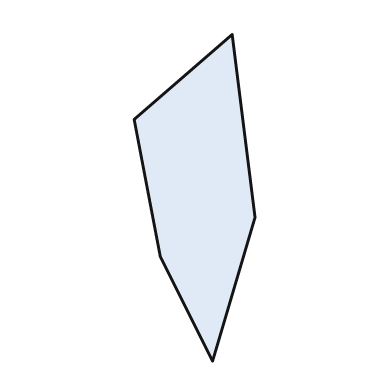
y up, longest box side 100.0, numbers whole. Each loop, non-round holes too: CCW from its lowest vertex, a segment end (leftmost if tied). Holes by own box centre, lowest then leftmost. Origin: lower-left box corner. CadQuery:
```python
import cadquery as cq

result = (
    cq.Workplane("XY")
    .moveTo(24.0, 0.0)
    .lineTo(37.0, 44.0)
    .lineTo(30.0, 100.0)
    .lineTo(0.0, 74.0)
    .lineTo(8.0, 32.0)
    .close()
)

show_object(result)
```